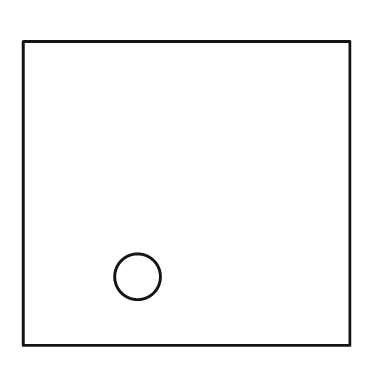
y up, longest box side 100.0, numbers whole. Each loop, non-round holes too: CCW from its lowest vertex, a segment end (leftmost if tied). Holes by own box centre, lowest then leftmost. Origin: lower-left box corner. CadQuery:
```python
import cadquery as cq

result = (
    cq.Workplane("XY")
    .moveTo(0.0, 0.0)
    .lineTo(100.0, 0.0)
    .lineTo(100.0, 93.0)
    .lineTo(0.0, 93.0)
    .close()
    .moveTo(35.0, 21.0)
    .circle(7.0)
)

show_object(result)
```